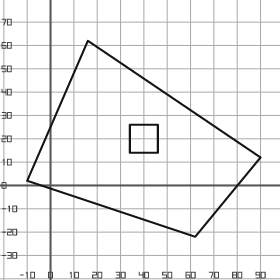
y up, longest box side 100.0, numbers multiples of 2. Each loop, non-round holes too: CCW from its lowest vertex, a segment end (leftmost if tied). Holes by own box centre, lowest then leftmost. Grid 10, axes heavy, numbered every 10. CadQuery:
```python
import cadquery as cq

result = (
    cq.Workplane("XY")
    .moveTo(62.0, -22.0)
    .lineTo(90.0, 12.0)
    .lineTo(16.0, 62.0)
    .lineTo(-10.0, 2.0)
    .close()
    .moveTo(34.0, 14.0)
    .lineTo(46.0, 14.0)
    .lineTo(46.0, 26.0)
    .lineTo(34.0, 26.0)
    .close()
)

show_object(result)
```